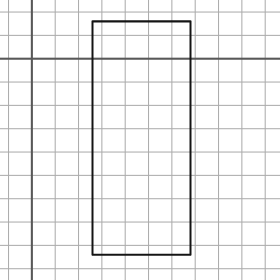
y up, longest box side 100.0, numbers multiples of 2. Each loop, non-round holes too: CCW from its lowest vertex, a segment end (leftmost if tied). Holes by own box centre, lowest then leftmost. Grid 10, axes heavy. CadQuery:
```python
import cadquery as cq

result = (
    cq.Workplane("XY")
    .moveTo(26.0, -84.0)
    .lineTo(68.0, -84.0)
    .lineTo(68.0, 16.0)
    .lineTo(26.0, 16.0)
    .close()
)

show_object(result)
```